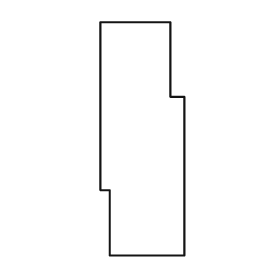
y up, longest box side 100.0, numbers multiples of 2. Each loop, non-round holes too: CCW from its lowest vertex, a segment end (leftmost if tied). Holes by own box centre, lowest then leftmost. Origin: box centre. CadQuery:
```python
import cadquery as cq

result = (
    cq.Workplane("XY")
    .moveTo(-14.0, -50.0)
    .lineTo(18.0, -50.0)
    .lineTo(18.0, 18.0)
    .lineTo(12.0, 18.0)
    .lineTo(12.0, 50.0)
    .lineTo(-18.0, 50.0)
    .lineTo(-18.0, -22.0)
    .lineTo(-14.0, -22.0)
    .close()
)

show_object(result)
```